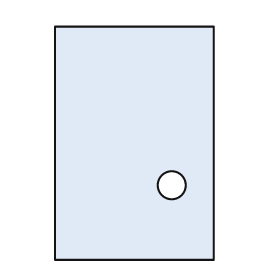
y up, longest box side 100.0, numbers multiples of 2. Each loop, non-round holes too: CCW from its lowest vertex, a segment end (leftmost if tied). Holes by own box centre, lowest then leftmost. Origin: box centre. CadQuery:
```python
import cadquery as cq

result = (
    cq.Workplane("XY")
    .moveTo(-34.0, -50.0)
    .lineTo(34.0, -50.0)
    .lineTo(34.0, 50.0)
    .lineTo(-34.0, 50.0)
    .close()
    .moveTo(16.0, -18.0)
    .circle(6.0)
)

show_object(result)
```